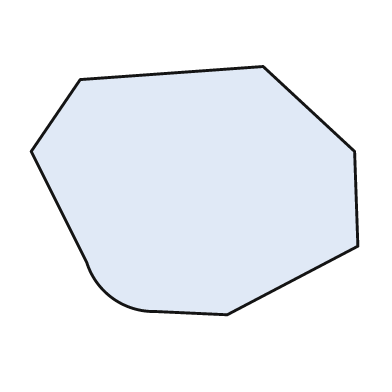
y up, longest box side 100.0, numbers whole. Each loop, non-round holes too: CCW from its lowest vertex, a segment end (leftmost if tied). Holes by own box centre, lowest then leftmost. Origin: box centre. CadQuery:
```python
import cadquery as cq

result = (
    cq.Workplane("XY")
    .moveTo(10.0, -38.0)
    .lineTo(50.0, -17.0)
    .lineTo(49.0, 12.0)
    .lineTo(21.0, 38.0)
    .lineTo(-35.0, 34.0)
    .lineTo(-50.0, 12.0)
    .lineTo(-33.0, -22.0)
    .threePointArc((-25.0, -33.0), (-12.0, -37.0))
    .close()
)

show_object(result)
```